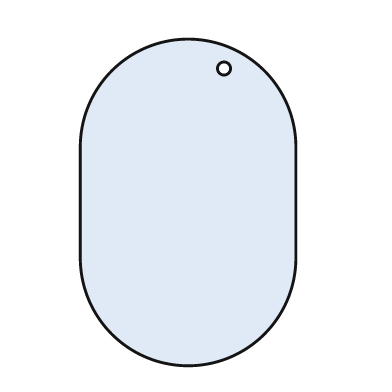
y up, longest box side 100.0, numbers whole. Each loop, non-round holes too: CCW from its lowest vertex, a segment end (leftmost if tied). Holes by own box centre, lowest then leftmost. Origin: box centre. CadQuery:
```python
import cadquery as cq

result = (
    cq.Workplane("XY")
    .moveTo(-33.0, -17.0)
    .threePointArc((0.0, -50.0), (33.0, -17.0))
    .lineTo(33.0, 17.0)
    .threePointArc((0.0, 50.0), (-33.0, 17.0))
    .close()
    .moveTo(11.0, 41.0)
    .circle(2.0)
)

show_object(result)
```